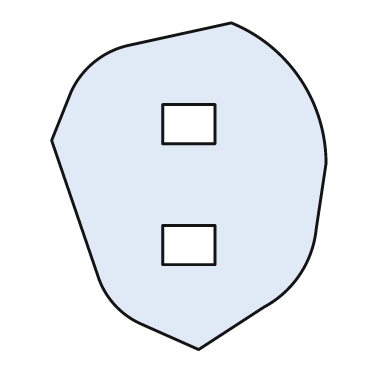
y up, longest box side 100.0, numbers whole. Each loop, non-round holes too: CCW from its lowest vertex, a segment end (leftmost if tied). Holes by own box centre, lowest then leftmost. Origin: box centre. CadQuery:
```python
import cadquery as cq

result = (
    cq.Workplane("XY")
    .moveTo(3.0, -50.0)
    .lineTo(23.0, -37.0)
    .threePointArc((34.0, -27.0), (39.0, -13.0))
    .lineTo(42.0, 7.0)
    .threePointArc((34.0, 33.0), (13.0, 50.0))
    .lineTo(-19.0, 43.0)
    .threePointArc((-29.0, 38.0), (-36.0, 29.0))
    .lineTo(-42.0, 14.0)
    .lineTo(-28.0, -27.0)
    .threePointArc((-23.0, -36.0), (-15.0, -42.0))
    .close()
    .moveTo(-8.0, -24.0)
    .lineTo(8.0, -24.0)
    .lineTo(8.0, -12.0)
    .lineTo(-8.0, -12.0)
    .close()
    .moveTo(-8.0, 13.0)
    .lineTo(8.0, 13.0)
    .lineTo(8.0, 25.0)
    .lineTo(-8.0, 25.0)
    .close()
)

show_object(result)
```